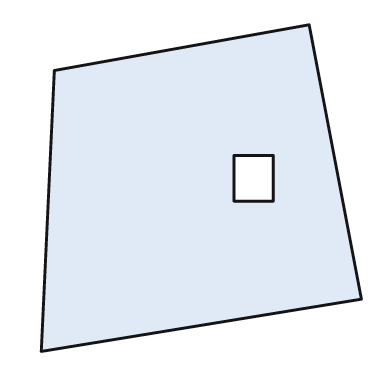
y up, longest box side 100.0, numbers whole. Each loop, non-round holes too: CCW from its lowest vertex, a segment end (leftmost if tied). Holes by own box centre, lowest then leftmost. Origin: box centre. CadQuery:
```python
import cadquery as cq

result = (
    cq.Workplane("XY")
    .moveTo(-49.0, -50.0)
    .lineTo(49.0, -34.0)
    .lineTo(33.0, 50.0)
    .lineTo(-45.0, 36.0)
    .close()
    .moveTo(10.0, -4.0)
    .lineTo(22.0, -4.0)
    .lineTo(22.0, 10.0)
    .lineTo(10.0, 10.0)
    .close()
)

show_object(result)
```